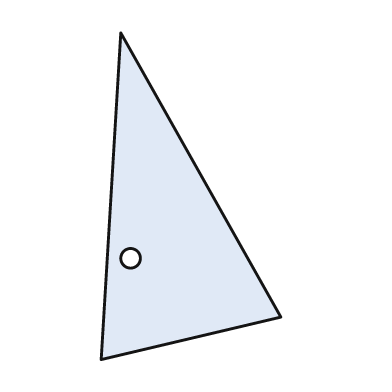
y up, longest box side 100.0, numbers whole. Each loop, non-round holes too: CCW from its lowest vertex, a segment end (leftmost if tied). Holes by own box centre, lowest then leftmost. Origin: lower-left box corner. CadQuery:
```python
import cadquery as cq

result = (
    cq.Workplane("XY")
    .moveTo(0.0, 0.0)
    .lineTo(55.0, 13.0)
    .lineTo(6.0, 100.0)
    .close()
    .moveTo(9.0, 31.0)
    .circle(3.0)
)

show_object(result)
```